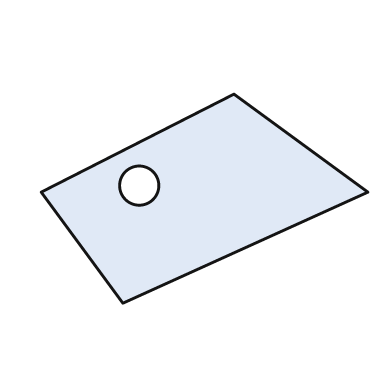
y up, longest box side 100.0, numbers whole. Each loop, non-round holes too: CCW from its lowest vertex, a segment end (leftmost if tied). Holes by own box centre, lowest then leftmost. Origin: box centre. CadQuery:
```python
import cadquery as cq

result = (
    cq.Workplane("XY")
    .moveTo(-25.0, -32.0)
    .lineTo(50.0, 2.0)
    .lineTo(9.0, 32.0)
    .lineTo(-50.0, 2.0)
    .close()
    .moveTo(-20.0, 4.0)
    .circle(6.0)
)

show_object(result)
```